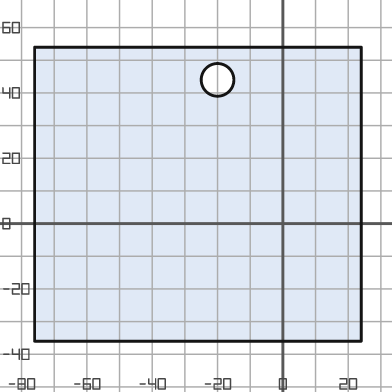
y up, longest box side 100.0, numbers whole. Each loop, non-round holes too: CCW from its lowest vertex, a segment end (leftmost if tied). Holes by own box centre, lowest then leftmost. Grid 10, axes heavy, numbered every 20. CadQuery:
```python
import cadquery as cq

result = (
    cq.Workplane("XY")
    .moveTo(-76.0, -36.0)
    .lineTo(24.0, -36.0)
    .lineTo(24.0, 54.0)
    .lineTo(-76.0, 54.0)
    .close()
    .moveTo(-20.0, 44.0)
    .circle(5.0)
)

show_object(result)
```